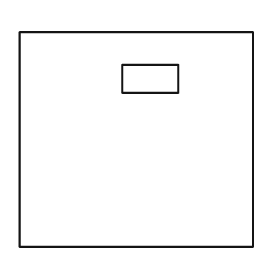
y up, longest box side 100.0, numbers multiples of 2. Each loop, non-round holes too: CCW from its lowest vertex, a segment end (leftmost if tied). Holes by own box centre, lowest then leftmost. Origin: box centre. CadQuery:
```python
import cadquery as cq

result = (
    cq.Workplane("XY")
    .moveTo(-50.0, -46.0)
    .lineTo(50.0, -46.0)
    .lineTo(50.0, 46.0)
    .lineTo(-50.0, 46.0)
    .close()
    .moveTo(-6.0, 20.0)
    .lineTo(18.0, 20.0)
    .lineTo(18.0, 32.0)
    .lineTo(-6.0, 32.0)
    .close()
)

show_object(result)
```